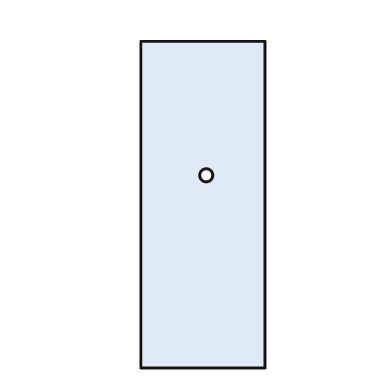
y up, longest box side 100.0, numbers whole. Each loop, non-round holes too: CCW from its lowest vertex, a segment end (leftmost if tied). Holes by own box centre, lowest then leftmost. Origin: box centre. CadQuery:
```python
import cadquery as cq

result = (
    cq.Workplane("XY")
    .moveTo(-19.0, -50.0)
    .lineTo(19.0, -50.0)
    .lineTo(19.0, 50.0)
    .lineTo(-19.0, 50.0)
    .close()
    .moveTo(1.0, 9.0)
    .circle(2.0)
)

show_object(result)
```